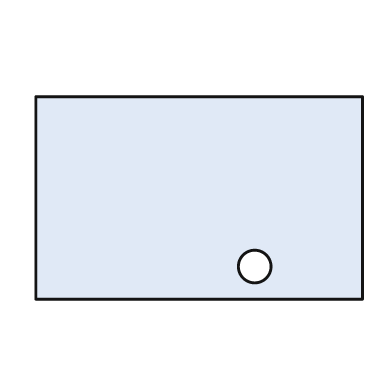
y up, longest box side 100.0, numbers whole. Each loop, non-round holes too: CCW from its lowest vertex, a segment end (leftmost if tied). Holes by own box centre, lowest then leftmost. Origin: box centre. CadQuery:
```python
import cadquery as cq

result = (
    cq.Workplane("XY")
    .moveTo(-50.0, -31.0)
    .lineTo(50.0, -31.0)
    .lineTo(50.0, 31.0)
    .lineTo(-50.0, 31.0)
    .close()
    .moveTo(17.0, -21.0)
    .circle(5.0)
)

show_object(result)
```